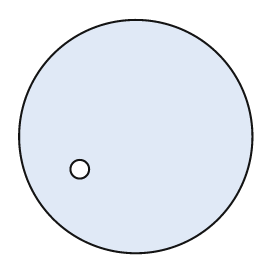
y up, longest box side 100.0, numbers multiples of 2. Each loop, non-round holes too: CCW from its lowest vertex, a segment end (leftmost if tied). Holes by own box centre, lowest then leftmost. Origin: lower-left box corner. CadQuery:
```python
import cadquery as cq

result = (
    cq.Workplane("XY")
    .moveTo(50.0, 50.0)
    .circle(50.0)
    .moveTo(26.0, 36.0)
    .circle(4.0)
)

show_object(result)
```